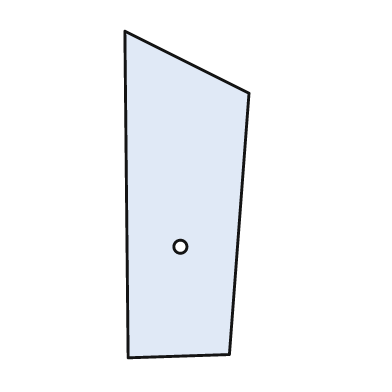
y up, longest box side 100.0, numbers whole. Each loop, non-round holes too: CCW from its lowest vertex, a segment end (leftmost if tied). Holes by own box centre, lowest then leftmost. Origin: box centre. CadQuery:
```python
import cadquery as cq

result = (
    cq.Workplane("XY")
    .moveTo(-18.0, -50.0)
    .lineTo(13.0, -49.0)
    .lineTo(19.0, 31.0)
    .lineTo(-19.0, 50.0)
    .close()
    .moveTo(-2.0, -16.0)
    .circle(2.0)
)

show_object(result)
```